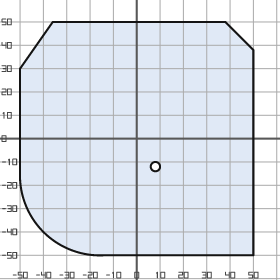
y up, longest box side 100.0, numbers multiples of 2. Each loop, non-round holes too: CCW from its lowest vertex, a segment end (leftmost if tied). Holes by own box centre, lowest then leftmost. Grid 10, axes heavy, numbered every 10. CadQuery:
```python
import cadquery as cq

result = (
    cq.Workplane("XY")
    .moveTo(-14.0, -50.0)
    .lineTo(50.0, -50.0)
    .lineTo(50.0, 38.0)
    .lineTo(38.0, 50.0)
    .lineTo(-36.0, 50.0)
    .lineTo(-50.0, 30.0)
    .lineTo(-50.0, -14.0)
    .threePointArc((-40.0, -40.0), (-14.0, -50.0))
    .close()
    .moveTo(8.0, -12.0)
    .circle(2.0)
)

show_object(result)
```